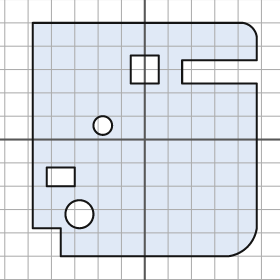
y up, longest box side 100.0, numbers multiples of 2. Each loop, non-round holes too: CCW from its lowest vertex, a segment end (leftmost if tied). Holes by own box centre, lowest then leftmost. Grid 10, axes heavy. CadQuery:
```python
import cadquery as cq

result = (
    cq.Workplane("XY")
    .moveTo(-36.0, -50.0)
    .lineTo(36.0, -50.0)
    .threePointArc((44.0, -46.0), (48.0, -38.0))
    .lineTo(48.0, 24.0)
    .lineTo(16.0, 24.0)
    .lineTo(16.0, 34.0)
    .lineTo(48.0, 34.0)
    .lineTo(48.0, 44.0)
    .threePointArc((46.0, 48.0), (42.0, 50.0))
    .lineTo(-48.0, 50.0)
    .lineTo(-48.0, -38.0)
    .lineTo(-36.0, -38.0)
    .close()
    .moveTo(-28.0, -32.0)
    .circle(6.0)
    .moveTo(-42.0, -20.0)
    .lineTo(-30.0, -20.0)
    .lineTo(-30.0, -12.0)
    .lineTo(-42.0, -12.0)
    .close()
    .moveTo(-18.0, 6.0)
    .circle(4.0)
    .moveTo(-6.0, 24.0)
    .lineTo(6.0, 24.0)
    .lineTo(6.0, 36.0)
    .lineTo(-6.0, 36.0)
    .close()
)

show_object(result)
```